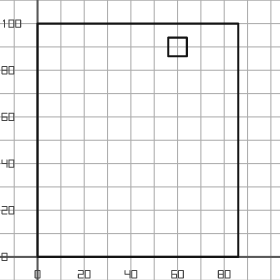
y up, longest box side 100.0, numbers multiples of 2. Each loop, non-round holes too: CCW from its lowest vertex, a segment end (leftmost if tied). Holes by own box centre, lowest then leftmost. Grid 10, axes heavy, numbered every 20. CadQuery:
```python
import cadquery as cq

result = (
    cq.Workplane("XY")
    .moveTo(0.0, 0.0)
    .lineTo(86.0, 0.0)
    .lineTo(86.0, 100.0)
    .lineTo(0.0, 100.0)
    .close()
    .moveTo(56.0, 86.0)
    .lineTo(64.0, 86.0)
    .lineTo(64.0, 94.0)
    .lineTo(56.0, 94.0)
    .close()
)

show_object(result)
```